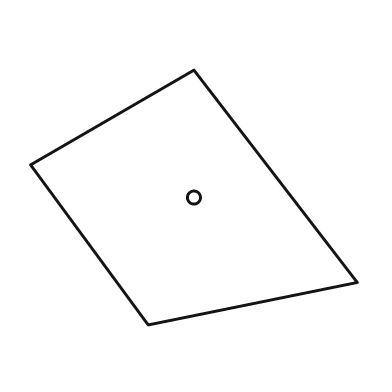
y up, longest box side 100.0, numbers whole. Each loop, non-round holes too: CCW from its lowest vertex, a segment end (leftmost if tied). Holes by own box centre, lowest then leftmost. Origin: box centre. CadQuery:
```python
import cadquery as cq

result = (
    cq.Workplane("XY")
    .moveTo(-14.0, -39.0)
    .lineTo(50.0, -26.0)
    .lineTo(0.0, 39.0)
    .lineTo(-50.0, 10.0)
    .close()
    .moveTo(0.0, 0.0)
    .circle(2.0)
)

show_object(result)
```